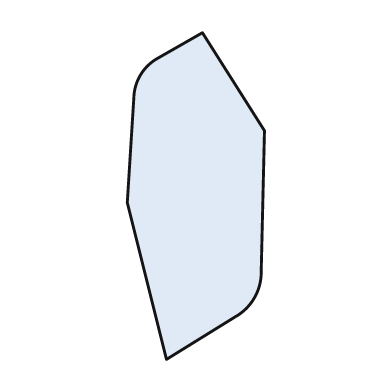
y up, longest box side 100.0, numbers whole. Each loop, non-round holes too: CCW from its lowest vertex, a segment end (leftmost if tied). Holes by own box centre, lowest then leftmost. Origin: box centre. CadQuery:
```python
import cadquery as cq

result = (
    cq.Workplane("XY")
    .moveTo(-9.0, -50.0)
    .lineTo(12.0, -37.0)
    .threePointArc((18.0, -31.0), (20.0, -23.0))
    .lineTo(21.0, 20.0)
    .lineTo(2.0, 50.0)
    .lineTo(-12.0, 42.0)
    .threePointArc((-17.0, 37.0), (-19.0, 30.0))
    .lineTo(-21.0, -2.0)
    .close()
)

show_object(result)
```